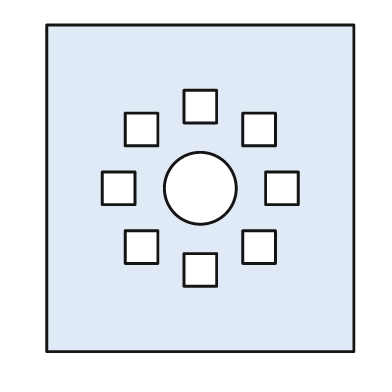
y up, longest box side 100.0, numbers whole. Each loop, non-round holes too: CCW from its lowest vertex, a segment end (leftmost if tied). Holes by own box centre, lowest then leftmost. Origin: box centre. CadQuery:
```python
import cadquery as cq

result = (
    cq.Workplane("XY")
    .moveTo(-47.0, -50.0)
    .lineTo(47.0, -50.0)
    .lineTo(47.0, 50.0)
    .lineTo(-47.0, 50.0)
    .close()
    .moveTo(-5.0, -30.0)
    .lineTo(5.0, -30.0)
    .lineTo(5.0, -20.0)
    .lineTo(-5.0, -20.0)
    .close()
    .moveTo(-23.0, -23.0)
    .lineTo(-13.0, -23.0)
    .lineTo(-13.0, -13.0)
    .lineTo(-23.0, -13.0)
    .close()
    .moveTo(13.0, -23.0)
    .lineTo(23.0, -23.0)
    .lineTo(23.0, -13.0)
    .lineTo(13.0, -13.0)
    .close()
    .moveTo(-30.0, -5.0)
    .lineTo(-20.0, -5.0)
    .lineTo(-20.0, 5.0)
    .lineTo(-30.0, 5.0)
    .close()
    .moveTo(0.0, 0.0)
    .circle(11.0)
    .moveTo(20.0, -5.0)
    .lineTo(30.0, -5.0)
    .lineTo(30.0, 5.0)
    .lineTo(20.0, 5.0)
    .close()
    .moveTo(-23.0, 13.0)
    .lineTo(-13.0, 13.0)
    .lineTo(-13.0, 23.0)
    .lineTo(-23.0, 23.0)
    .close()
    .moveTo(13.0, 13.0)
    .lineTo(23.0, 13.0)
    .lineTo(23.0, 23.0)
    .lineTo(13.0, 23.0)
    .close()
    .moveTo(-5.0, 20.0)
    .lineTo(5.0, 20.0)
    .lineTo(5.0, 30.0)
    .lineTo(-5.0, 30.0)
    .close()
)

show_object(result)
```